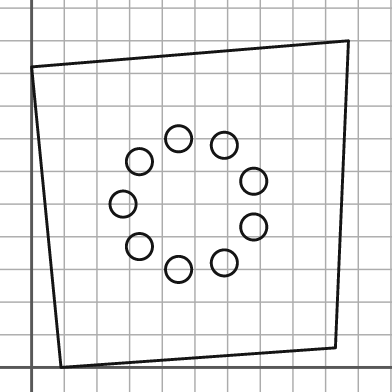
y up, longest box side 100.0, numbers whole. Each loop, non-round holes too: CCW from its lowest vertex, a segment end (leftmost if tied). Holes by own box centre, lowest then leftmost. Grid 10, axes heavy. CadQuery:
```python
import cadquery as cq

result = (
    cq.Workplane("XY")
    .moveTo(9.0, 0.0)
    .lineTo(93.0, 6.0)
    .lineTo(97.0, 100.0)
    .lineTo(0.0, 92.0)
    .close()
    .moveTo(45.0, 30.0)
    .circle(4.0)
    .moveTo(59.0, 32.0)
    .circle(4.0)
    .moveTo(33.0, 37.0)
    .circle(4.0)
    .moveTo(68.0, 43.0)
    .circle(4.0)
    .moveTo(28.0, 50.0)
    .circle(4.0)
    .moveTo(68.0, 57.0)
    .circle(4.0)
    .moveTo(33.0, 63.0)
    .circle(4.0)
    .moveTo(59.0, 68.0)
    .circle(4.0)
    .moveTo(45.0, 70.0)
    .circle(4.0)
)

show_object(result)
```